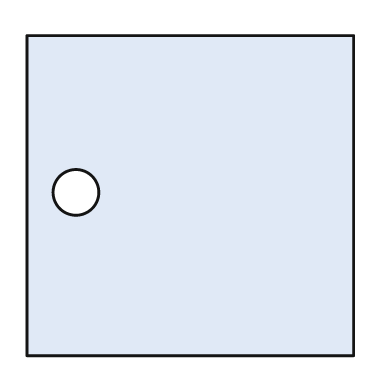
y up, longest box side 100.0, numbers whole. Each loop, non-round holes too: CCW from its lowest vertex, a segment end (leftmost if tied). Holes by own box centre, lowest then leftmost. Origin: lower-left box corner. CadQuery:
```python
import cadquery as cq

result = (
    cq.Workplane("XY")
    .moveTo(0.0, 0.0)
    .lineTo(100.0, 0.0)
    .lineTo(100.0, 98.0)
    .lineTo(0.0, 98.0)
    .close()
    .moveTo(15.0, 50.0)
    .circle(7.0)
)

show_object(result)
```